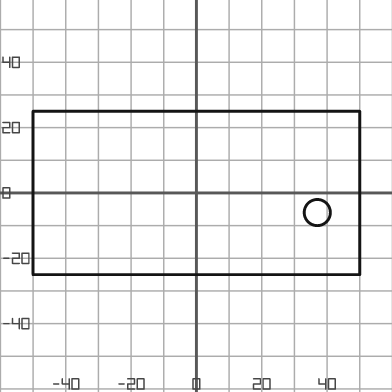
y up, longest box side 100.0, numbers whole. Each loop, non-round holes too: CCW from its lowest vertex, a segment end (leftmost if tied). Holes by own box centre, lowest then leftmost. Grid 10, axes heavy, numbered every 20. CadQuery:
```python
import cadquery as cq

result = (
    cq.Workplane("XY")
    .moveTo(-50.0, -25.0)
    .lineTo(50.0, -25.0)
    .lineTo(50.0, 25.0)
    .lineTo(-50.0, 25.0)
    .close()
    .moveTo(37.0, -6.0)
    .circle(4.0)
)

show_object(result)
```